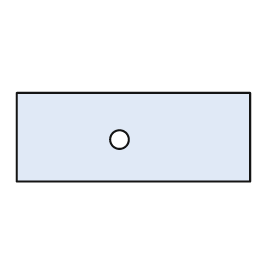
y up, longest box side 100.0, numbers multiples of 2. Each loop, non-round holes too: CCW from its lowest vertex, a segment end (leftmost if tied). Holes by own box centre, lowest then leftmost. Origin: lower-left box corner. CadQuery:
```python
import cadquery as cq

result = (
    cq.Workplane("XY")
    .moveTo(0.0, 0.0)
    .lineTo(100.0, 0.0)
    .lineTo(100.0, 38.0)
    .lineTo(0.0, 38.0)
    .close()
    .moveTo(44.0, 18.0)
    .circle(4.0)
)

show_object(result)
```